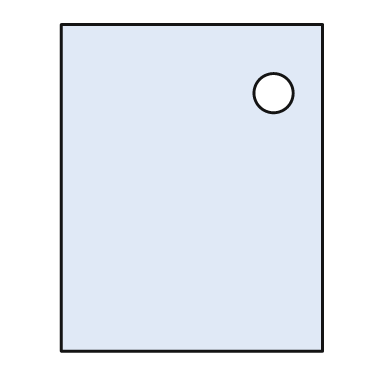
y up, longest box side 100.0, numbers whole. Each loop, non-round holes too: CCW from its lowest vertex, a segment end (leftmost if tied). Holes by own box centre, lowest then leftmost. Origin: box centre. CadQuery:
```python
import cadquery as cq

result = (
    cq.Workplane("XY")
    .moveTo(-40.0, -50.0)
    .lineTo(40.0, -50.0)
    .lineTo(40.0, 50.0)
    .lineTo(-40.0, 50.0)
    .close()
    .moveTo(25.0, 29.0)
    .circle(6.0)
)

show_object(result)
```